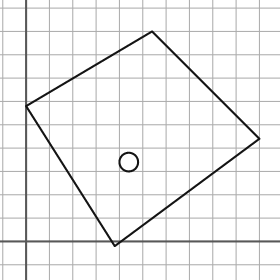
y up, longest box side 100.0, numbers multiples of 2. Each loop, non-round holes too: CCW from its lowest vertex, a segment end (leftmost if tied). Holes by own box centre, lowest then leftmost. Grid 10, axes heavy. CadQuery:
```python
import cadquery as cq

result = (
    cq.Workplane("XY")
    .moveTo(38.0, -2.0)
    .lineTo(100.0, 44.0)
    .lineTo(54.0, 90.0)
    .lineTo(0.0, 58.0)
    .close()
    .moveTo(44.0, 34.0)
    .circle(4.0)
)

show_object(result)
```